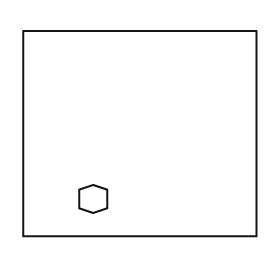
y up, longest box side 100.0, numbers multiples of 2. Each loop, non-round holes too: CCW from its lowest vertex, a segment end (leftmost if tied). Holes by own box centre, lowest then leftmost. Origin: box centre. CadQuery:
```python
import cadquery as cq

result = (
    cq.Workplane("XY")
    .moveTo(-50.0, -44.0)
    .lineTo(50.0, -44.0)
    .lineTo(50.0, 44.0)
    .lineTo(-50.0, 44.0)
    .close()
    .moveTo(-20.0, -34.0)
    .lineTo(-14.0, -32.0)
    .lineTo(-14.0, -24.0)
    .lineTo(-20.0, -22.0)
    .lineTo(-26.0, -24.0)
    .lineTo(-26.0, -32.0)
    .close()
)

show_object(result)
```